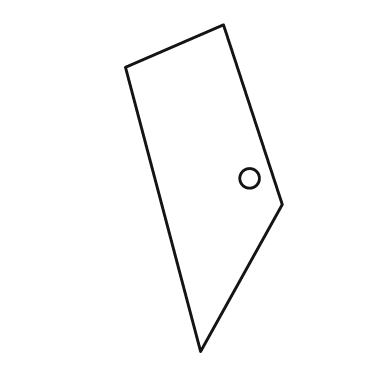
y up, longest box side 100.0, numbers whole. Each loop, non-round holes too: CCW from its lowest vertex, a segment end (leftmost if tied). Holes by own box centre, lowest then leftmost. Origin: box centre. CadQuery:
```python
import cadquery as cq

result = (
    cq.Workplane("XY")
    .moveTo(-1.0, -50.0)
    .lineTo(24.0, -5.0)
    .lineTo(6.0, 50.0)
    .lineTo(-24.0, 37.0)
    .close()
    .moveTo(14.0, 3.0)
    .circle(3.0)
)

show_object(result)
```